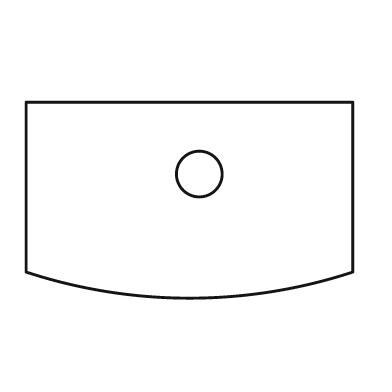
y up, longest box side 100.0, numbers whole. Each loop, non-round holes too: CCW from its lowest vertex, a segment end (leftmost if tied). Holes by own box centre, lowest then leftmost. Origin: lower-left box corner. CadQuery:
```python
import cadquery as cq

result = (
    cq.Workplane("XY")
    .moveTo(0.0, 8.0)
    .threePointArc((50.0, 0.0), (100.0, 8.0))
    .lineTo(100.0, 60.0)
    .lineTo(0.0, 60.0)
    .close()
    .moveTo(53.0, 38.0)
    .circle(7.0)
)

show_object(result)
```